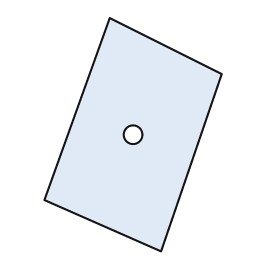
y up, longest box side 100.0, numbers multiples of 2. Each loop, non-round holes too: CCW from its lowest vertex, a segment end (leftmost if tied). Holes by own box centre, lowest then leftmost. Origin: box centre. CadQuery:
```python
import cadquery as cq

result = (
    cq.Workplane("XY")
    .moveTo(12.0, -50.0)
    .lineTo(38.0, 26.0)
    .lineTo(-10.0, 50.0)
    .lineTo(-38.0, -28.0)
    .close()
    .moveTo(0.0, 0.0)
    .circle(4.0)
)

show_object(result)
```